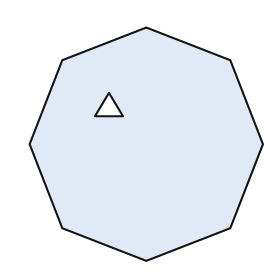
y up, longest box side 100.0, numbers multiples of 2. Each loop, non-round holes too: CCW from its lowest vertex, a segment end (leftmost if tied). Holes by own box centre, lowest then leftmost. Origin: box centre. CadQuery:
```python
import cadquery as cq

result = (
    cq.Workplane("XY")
    .moveTo(0.0, -50.0)
    .lineTo(36.0, -36.0)
    .lineTo(50.0, 0.0)
    .lineTo(36.0, 36.0)
    .lineTo(0.0, 50.0)
    .lineTo(-36.0, 36.0)
    .lineTo(-50.0, 0.0)
    .lineTo(-36.0, -36.0)
    .close()
    .moveTo(-22.0, 12.0)
    .lineTo(-10.0, 12.0)
    .lineTo(-16.0, 22.0)
    .close()
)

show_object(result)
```